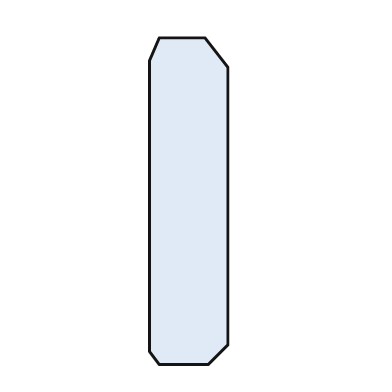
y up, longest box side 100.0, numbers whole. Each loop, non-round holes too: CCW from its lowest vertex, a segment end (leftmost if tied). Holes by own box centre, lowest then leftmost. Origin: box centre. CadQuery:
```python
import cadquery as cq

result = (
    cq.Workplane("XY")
    .moveTo(-9.0, -50.0)
    .lineTo(6.0, -50.0)
    .lineTo(12.0, -44.0)
    .lineTo(12.0, 41.0)
    .lineTo(5.0, 50.0)
    .lineTo(-9.0, 50.0)
    .lineTo(-12.0, 43.0)
    .lineTo(-12.0, -46.0)
    .close()
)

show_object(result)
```